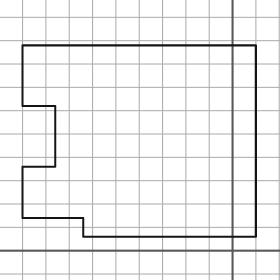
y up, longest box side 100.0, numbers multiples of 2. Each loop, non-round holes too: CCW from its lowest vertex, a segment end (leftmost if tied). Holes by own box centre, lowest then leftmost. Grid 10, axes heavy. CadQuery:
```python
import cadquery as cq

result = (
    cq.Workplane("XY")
    .moveTo(-64.0, 6.0)
    .lineTo(10.0, 6.0)
    .lineTo(10.0, 88.0)
    .lineTo(-90.0, 88.0)
    .lineTo(-90.0, 62.0)
    .lineTo(-76.0, 62.0)
    .lineTo(-76.0, 36.0)
    .lineTo(-90.0, 36.0)
    .lineTo(-90.0, 14.0)
    .lineTo(-64.0, 14.0)
    .close()
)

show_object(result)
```